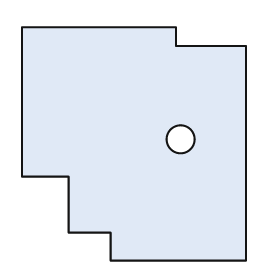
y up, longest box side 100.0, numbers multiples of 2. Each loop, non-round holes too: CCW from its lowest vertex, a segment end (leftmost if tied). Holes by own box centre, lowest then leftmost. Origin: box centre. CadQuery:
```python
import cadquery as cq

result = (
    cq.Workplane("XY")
    .moveTo(-10.0, -50.0)
    .lineTo(48.0, -50.0)
    .lineTo(48.0, 42.0)
    .lineTo(18.0, 42.0)
    .lineTo(18.0, 50.0)
    .lineTo(-48.0, 50.0)
    .lineTo(-48.0, -14.0)
    .lineTo(-28.0, -14.0)
    .lineTo(-28.0, -38.0)
    .lineTo(-10.0, -38.0)
    .close()
    .moveTo(20.0, 2.0)
    .circle(6.0)
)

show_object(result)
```